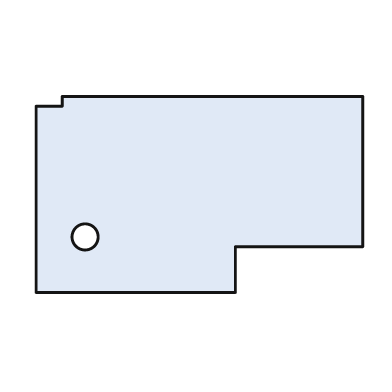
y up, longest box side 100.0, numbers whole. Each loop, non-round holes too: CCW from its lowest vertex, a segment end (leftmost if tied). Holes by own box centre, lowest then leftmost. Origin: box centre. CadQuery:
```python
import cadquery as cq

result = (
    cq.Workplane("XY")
    .moveTo(-50.0, -30.0)
    .lineTo(11.0, -30.0)
    .lineTo(11.0, -16.0)
    .lineTo(50.0, -16.0)
    .lineTo(50.0, 30.0)
    .lineTo(-42.0, 30.0)
    .lineTo(-42.0, 27.0)
    .lineTo(-50.0, 27.0)
    .close()
    .moveTo(-35.0, -13.0)
    .circle(4.0)
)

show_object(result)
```